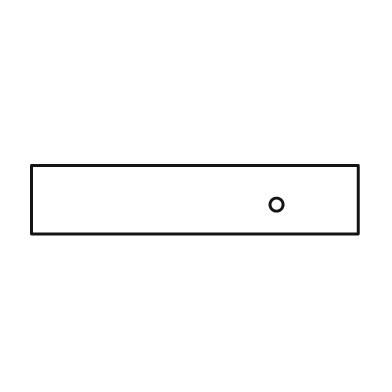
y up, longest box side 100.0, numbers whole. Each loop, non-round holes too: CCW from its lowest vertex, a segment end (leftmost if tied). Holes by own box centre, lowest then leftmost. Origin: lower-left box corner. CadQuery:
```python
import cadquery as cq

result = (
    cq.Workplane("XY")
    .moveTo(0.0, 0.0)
    .lineTo(100.0, 0.0)
    .lineTo(100.0, 21.0)
    .lineTo(0.0, 21.0)
    .close()
    .moveTo(75.0, 9.0)
    .circle(2.0)
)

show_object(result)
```